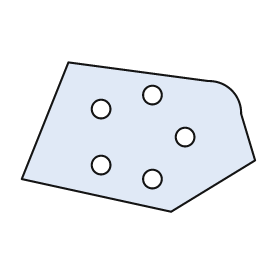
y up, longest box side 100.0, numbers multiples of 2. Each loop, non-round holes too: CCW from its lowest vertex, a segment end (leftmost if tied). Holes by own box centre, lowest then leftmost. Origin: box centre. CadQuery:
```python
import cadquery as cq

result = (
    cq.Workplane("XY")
    .moveTo(14.0, -32.0)
    .lineTo(50.0, -10.0)
    .lineTo(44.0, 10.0)
    .threePointArc((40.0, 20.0), (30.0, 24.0))
    .lineTo(-30.0, 32.0)
    .lineTo(-50.0, -18.0)
    .close()
    .moveTo(6.0, -18.0)
    .circle(4.0)
    .moveTo(-16.0, -12.0)
    .circle(4.0)
    .moveTo(20.0, 0.0)
    .circle(4.0)
    .moveTo(-16.0, 12.0)
    .circle(4.0)
    .moveTo(6.0, 18.0)
    .circle(4.0)
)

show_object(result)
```